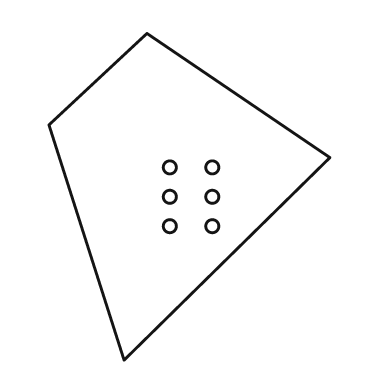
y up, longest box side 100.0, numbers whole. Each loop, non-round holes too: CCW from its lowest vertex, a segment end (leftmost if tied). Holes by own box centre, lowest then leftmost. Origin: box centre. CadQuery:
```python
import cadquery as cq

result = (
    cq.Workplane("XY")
    .moveTo(-20.0, -50.0)
    .lineTo(43.0, 12.0)
    .lineTo(-13.0, 50.0)
    .lineTo(-43.0, 22.0)
    .close()
    .moveTo(-6.0, -9.0)
    .circle(2.0)
    .moveTo(7.0, -9.0)
    .circle(2.0)
    .moveTo(-6.0, 0.0)
    .circle(2.0)
    .moveTo(7.0, 0.0)
    .circle(2.0)
    .moveTo(-6.0, 9.0)
    .circle(2.0)
    .moveTo(7.0, 9.0)
    .circle(2.0)
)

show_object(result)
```